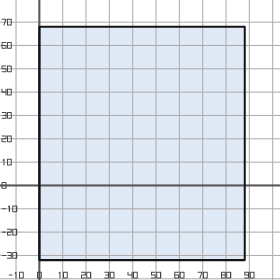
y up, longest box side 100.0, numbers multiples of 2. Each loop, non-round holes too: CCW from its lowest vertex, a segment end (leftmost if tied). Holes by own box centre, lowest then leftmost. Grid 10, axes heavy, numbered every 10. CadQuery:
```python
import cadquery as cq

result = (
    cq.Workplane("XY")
    .moveTo(0.0, -32.0)
    .lineTo(88.0, -32.0)
    .lineTo(88.0, 68.0)
    .lineTo(0.0, 68.0)
    .close()
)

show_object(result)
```